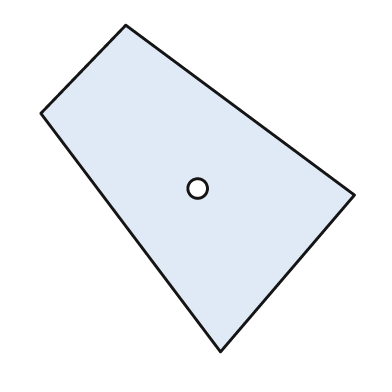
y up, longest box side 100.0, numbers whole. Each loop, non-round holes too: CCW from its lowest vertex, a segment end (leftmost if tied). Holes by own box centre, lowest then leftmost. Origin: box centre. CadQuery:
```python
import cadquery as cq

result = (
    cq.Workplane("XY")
    .moveTo(7.0, -50.0)
    .lineTo(48.0, -2.0)
    .lineTo(-22.0, 50.0)
    .lineTo(-48.0, 23.0)
    .close()
    .moveTo(0.0, 0.0)
    .circle(3.0)
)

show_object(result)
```